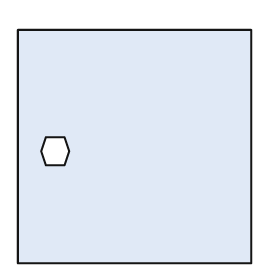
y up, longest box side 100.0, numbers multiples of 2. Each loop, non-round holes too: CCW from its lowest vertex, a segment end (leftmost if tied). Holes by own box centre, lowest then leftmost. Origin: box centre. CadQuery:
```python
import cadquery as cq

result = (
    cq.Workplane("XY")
    .moveTo(-50.0, -50.0)
    .lineTo(50.0, -50.0)
    .lineTo(50.0, 50.0)
    .lineTo(-50.0, 50.0)
    .close()
    .moveTo(-38.0, -8.0)
    .lineTo(-30.0, -8.0)
    .lineTo(-28.0, -2.0)
    .lineTo(-30.0, 4.0)
    .lineTo(-38.0, 4.0)
    .lineTo(-40.0, -2.0)
    .close()
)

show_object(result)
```